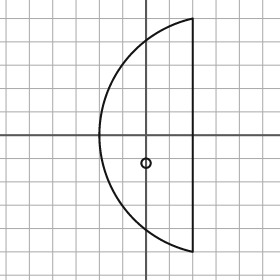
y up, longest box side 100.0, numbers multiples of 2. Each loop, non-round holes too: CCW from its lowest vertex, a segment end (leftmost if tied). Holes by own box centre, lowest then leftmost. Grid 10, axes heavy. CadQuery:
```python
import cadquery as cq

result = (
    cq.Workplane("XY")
    .moveTo(20.0, -50.0)
    .lineTo(20.0, 50.0)
    .threePointArc((-20.0, 0.0), (20.0, -50.0))
    .close()
    .moveTo(0.0, -12.0)
    .circle(2.0)
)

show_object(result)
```